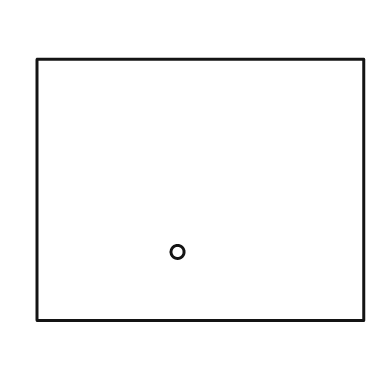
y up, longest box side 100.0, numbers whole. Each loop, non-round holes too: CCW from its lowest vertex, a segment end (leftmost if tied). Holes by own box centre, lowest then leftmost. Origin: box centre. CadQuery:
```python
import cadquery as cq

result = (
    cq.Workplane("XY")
    .moveTo(-50.0, -40.0)
    .lineTo(50.0, -40.0)
    .lineTo(50.0, 40.0)
    .lineTo(-50.0, 40.0)
    .close()
    .moveTo(-7.0, -19.0)
    .circle(2.0)
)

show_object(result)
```